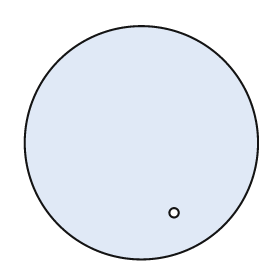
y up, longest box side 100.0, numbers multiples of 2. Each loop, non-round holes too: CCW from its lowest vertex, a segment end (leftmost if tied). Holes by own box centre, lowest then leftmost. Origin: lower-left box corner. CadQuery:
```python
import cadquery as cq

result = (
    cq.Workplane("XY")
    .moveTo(50.0, 50.0)
    .circle(50.0)
    .moveTo(64.0, 20.0)
    .circle(2.0)
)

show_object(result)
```